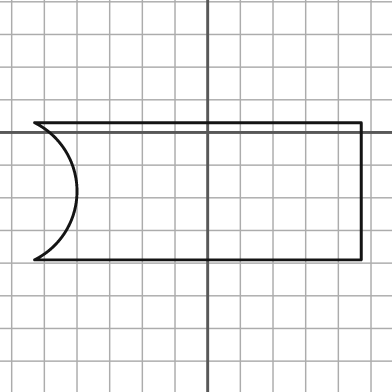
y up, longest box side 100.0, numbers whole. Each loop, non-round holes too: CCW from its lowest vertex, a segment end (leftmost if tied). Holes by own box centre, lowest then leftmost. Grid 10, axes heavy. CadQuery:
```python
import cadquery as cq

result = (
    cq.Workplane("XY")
    .moveTo(-53.0, -39.0)
    .lineTo(47.0, -39.0)
    .lineTo(47.0, 3.0)
    .lineTo(-53.0, 3.0)
    .threePointArc((-40.0, -18.0), (-53.0, -39.0))
    .close()
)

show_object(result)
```